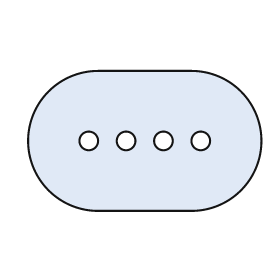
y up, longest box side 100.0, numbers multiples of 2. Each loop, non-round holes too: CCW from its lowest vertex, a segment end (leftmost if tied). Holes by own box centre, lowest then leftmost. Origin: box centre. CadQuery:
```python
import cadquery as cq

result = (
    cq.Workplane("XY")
    .moveTo(-20.0, -30.0)
    .lineTo(20.0, -30.0)
    .threePointArc((50.0, 0.0), (20.0, 30.0))
    .lineTo(-20.0, 30.0)
    .threePointArc((-50.0, 0.0), (-20.0, -30.0))
    .close()
    .moveTo(-24.0, 0.0)
    .circle(4.0)
    .moveTo(-8.0, 0.0)
    .circle(4.0)
    .moveTo(8.0, 0.0)
    .circle(4.0)
    .moveTo(24.0, 0.0)
    .circle(4.0)
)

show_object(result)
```